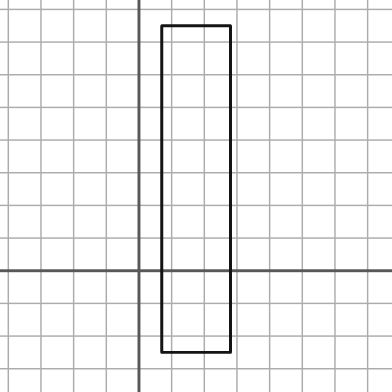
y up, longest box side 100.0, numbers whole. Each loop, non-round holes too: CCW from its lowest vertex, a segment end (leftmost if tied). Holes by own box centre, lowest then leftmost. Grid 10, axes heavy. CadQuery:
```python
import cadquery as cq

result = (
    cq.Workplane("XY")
    .moveTo(7.0, -25.0)
    .lineTo(28.0, -25.0)
    .lineTo(28.0, 75.0)
    .lineTo(7.0, 75.0)
    .close()
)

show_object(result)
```